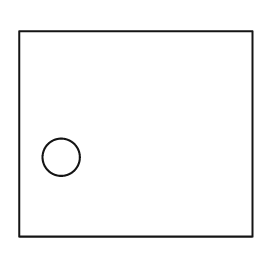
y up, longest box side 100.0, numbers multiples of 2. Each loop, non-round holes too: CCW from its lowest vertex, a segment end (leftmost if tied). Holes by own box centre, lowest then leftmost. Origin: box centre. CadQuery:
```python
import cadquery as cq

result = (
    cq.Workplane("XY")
    .moveTo(-50.0, -44.0)
    .lineTo(50.0, -44.0)
    .lineTo(50.0, 44.0)
    .lineTo(-50.0, 44.0)
    .close()
    .moveTo(-32.0, -10.0)
    .circle(8.0)
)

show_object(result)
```